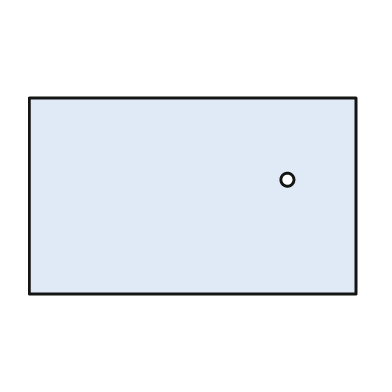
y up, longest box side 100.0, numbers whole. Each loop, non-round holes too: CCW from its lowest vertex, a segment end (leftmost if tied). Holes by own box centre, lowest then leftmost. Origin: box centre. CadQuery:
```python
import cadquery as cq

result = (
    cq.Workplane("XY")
    .moveTo(-50.0, -30.0)
    .lineTo(50.0, -30.0)
    .lineTo(50.0, 30.0)
    .lineTo(-50.0, 30.0)
    .close()
    .moveTo(29.0, 5.0)
    .circle(2.0)
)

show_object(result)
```